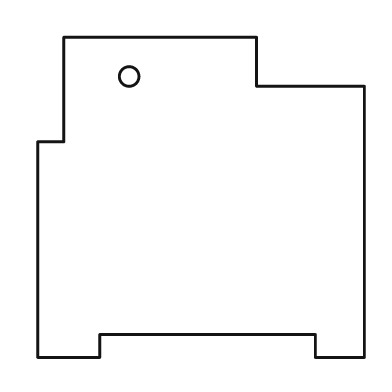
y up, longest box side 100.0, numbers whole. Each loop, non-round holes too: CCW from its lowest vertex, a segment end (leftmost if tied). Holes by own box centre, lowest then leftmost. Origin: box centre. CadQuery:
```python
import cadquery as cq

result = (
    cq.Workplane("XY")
    .moveTo(-50.0, -49.0)
    .lineTo(-31.0, -49.0)
    .lineTo(-31.0, -42.0)
    .lineTo(35.0, -42.0)
    .lineTo(35.0, -49.0)
    .lineTo(50.0, -49.0)
    .lineTo(50.0, 34.0)
    .lineTo(17.0, 34.0)
    .lineTo(17.0, 49.0)
    .lineTo(-42.0, 49.0)
    .lineTo(-42.0, 17.0)
    .lineTo(-50.0, 17.0)
    .close()
    .moveTo(-22.0, 37.0)
    .circle(3.0)
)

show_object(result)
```